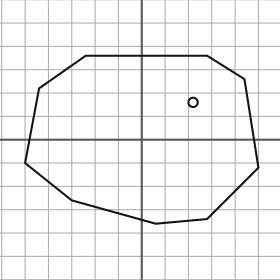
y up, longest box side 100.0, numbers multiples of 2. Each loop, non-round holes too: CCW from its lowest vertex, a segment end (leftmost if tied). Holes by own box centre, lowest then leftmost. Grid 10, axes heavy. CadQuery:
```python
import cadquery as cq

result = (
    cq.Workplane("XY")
    .moveTo(6.0, -36.0)
    .lineTo(28.0, -34.0)
    .lineTo(50.0, -12.0)
    .lineTo(44.0, 26.0)
    .lineTo(28.0, 36.0)
    .lineTo(-24.0, 36.0)
    .lineTo(-44.0, 22.0)
    .lineTo(-50.0, -10.0)
    .lineTo(-30.0, -26.0)
    .close()
    .moveTo(22.0, 16.0)
    .circle(2.0)
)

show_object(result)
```